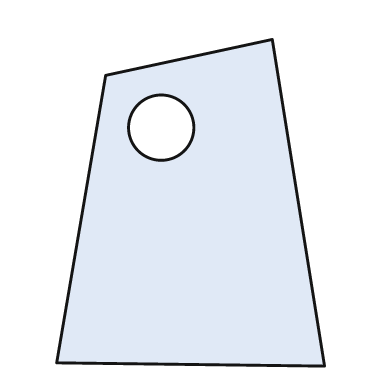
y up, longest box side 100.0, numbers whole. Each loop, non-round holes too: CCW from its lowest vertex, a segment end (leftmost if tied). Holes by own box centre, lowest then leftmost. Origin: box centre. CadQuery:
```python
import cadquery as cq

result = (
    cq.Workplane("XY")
    .moveTo(41.0, -50.0)
    .lineTo(25.0, 50.0)
    .lineTo(-26.0, 39.0)
    .lineTo(-41.0, -49.0)
    .close()
    .moveTo(-9.0, 23.0)
    .circle(10.0)
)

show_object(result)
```